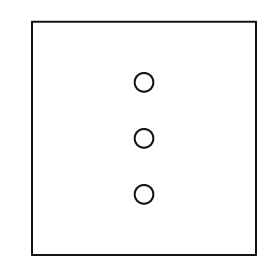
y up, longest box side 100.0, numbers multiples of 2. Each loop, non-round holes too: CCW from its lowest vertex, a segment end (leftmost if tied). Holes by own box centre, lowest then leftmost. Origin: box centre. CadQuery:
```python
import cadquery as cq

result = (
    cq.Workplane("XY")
    .moveTo(-48.0, -50.0)
    .lineTo(48.0, -50.0)
    .lineTo(48.0, 50.0)
    .lineTo(-48.0, 50.0)
    .close()
    .moveTo(0.0, -24.0)
    .circle(4.0)
    .moveTo(0.0, 0.0)
    .circle(4.0)
    .moveTo(0.0, 24.0)
    .circle(4.0)
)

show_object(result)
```